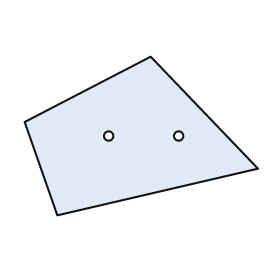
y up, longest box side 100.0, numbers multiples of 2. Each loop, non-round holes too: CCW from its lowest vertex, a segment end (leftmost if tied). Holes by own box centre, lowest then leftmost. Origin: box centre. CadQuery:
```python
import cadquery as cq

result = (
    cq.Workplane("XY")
    .moveTo(-36.0, -34.0)
    .lineTo(50.0, -14.0)
    .lineTo(4.0, 34.0)
    .lineTo(-50.0, 6.0)
    .close()
    .moveTo(-14.0, 0.0)
    .circle(2.0)
    .moveTo(16.0, 0.0)
    .circle(2.0)
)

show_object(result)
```